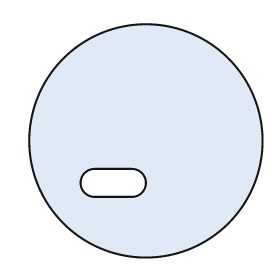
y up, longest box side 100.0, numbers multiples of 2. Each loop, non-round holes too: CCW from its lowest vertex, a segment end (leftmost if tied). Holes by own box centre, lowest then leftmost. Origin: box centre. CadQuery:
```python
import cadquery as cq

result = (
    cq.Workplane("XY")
    .moveTo(0.0, 0.0)
    .circle(50.0)
    .moveTo(-22.0, -24.0)
    .lineTo(-6.0, -24.0)
    .threePointArc((0.0, -18.0), (-6.0, -12.0))
    .lineTo(-22.0, -12.0)
    .threePointArc((-28.0, -18.0), (-22.0, -24.0))
    .close()
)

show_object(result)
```